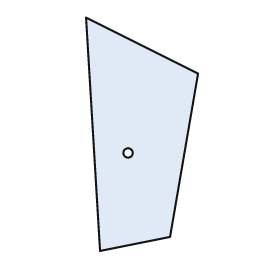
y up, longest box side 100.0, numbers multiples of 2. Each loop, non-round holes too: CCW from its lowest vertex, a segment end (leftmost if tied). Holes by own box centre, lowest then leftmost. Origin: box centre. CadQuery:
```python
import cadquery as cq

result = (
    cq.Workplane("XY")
    .moveTo(-18.0, -50.0)
    .lineTo(12.0, -44.0)
    .lineTo(24.0, 26.0)
    .lineTo(-24.0, 50.0)
    .close()
    .moveTo(-6.0, -8.0)
    .circle(2.0)
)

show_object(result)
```